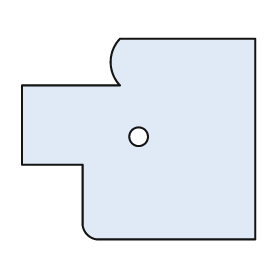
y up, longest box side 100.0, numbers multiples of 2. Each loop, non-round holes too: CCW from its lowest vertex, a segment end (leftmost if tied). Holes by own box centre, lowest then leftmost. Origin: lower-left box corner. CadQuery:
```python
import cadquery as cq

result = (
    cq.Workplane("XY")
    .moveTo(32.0, 0.0)
    .lineTo(100.0, 0.0)
    .lineTo(100.0, 86.0)
    .lineTo(42.0, 86.0)
    .threePointArc((38.0, 76.0), (42.0, 66.0))
    .lineTo(0.0, 66.0)
    .lineTo(0.0, 32.0)
    .lineTo(26.0, 32.0)
    .lineTo(26.0, 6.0)
    .threePointArc((28.0, 2.0), (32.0, 0.0))
    .close()
    .moveTo(50.0, 44.0)
    .circle(4.0)
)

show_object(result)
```